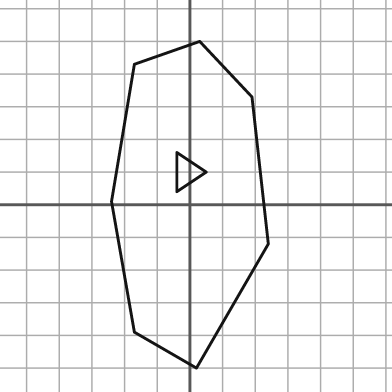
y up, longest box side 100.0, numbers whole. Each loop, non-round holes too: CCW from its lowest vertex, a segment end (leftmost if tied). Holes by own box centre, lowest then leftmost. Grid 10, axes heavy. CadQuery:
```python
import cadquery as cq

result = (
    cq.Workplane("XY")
    .moveTo(2.0, -50.0)
    .lineTo(24.0, -12.0)
    .lineTo(19.0, 33.0)
    .lineTo(3.0, 50.0)
    .lineTo(-17.0, 43.0)
    .lineTo(-24.0, 1.0)
    .lineTo(-17.0, -39.0)
    .close()
    .moveTo(-4.0, 4.0)
    .lineTo(5.0, 10.0)
    .lineTo(-4.0, 16.0)
    .close()
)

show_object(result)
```